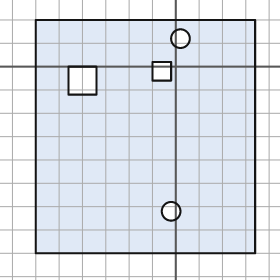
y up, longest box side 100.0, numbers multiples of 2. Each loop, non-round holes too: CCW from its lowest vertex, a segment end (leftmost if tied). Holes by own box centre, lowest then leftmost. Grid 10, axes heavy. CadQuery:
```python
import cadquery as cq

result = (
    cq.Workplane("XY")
    .moveTo(-60.0, -80.0)
    .lineTo(34.0, -80.0)
    .lineTo(34.0, 20.0)
    .lineTo(-60.0, 20.0)
    .close()
    .moveTo(-2.0, -62.0)
    .circle(4.0)
    .moveTo(-46.0, -12.0)
    .lineTo(-34.0, -12.0)
    .lineTo(-34.0, 0.0)
    .lineTo(-46.0, 0.0)
    .close()
    .moveTo(-10.0, -6.0)
    .lineTo(-2.0, -6.0)
    .lineTo(-2.0, 2.0)
    .lineTo(-10.0, 2.0)
    .close()
    .moveTo(2.0, 12.0)
    .circle(4.0)
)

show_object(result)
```